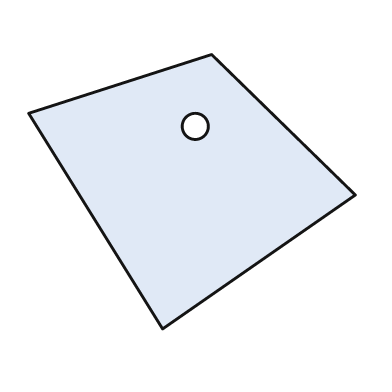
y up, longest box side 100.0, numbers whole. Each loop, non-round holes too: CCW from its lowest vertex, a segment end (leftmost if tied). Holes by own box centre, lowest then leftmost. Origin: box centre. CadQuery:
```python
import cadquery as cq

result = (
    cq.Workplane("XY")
    .moveTo(-9.0, -42.0)
    .lineTo(50.0, -1.0)
    .lineTo(6.0, 42.0)
    .lineTo(-50.0, 24.0)
    .close()
    .moveTo(1.0, 20.0)
    .circle(4.0)
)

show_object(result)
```